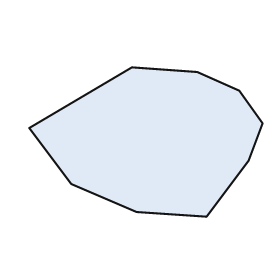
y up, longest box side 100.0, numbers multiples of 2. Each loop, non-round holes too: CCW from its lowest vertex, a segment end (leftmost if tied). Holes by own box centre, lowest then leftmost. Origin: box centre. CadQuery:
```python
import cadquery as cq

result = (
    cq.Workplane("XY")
    .moveTo(26.0, -32.0)
    .lineTo(44.0, -8.0)
    .lineTo(50.0, 8.0)
    .lineTo(40.0, 22.0)
    .lineTo(22.0, 30.0)
    .lineTo(-6.0, 32.0)
    .lineTo(-50.0, 6.0)
    .lineTo(-32.0, -18.0)
    .lineTo(-4.0, -30.0)
    .close()
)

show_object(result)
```